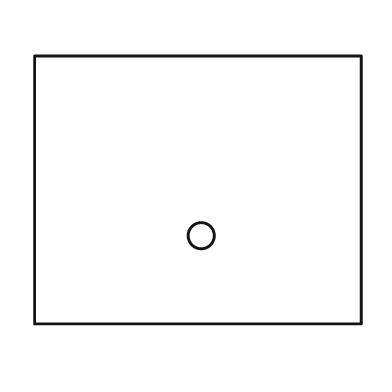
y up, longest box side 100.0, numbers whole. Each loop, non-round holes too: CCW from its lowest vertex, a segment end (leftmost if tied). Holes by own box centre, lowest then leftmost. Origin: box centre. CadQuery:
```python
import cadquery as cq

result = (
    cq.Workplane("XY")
    .moveTo(-50.0, -41.0)
    .lineTo(50.0, -41.0)
    .lineTo(50.0, 41.0)
    .lineTo(-50.0, 41.0)
    .close()
    .moveTo(1.0, -14.0)
    .circle(4.0)
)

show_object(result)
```